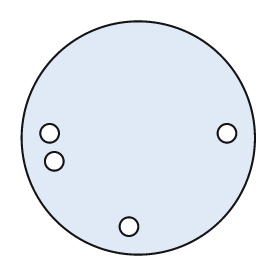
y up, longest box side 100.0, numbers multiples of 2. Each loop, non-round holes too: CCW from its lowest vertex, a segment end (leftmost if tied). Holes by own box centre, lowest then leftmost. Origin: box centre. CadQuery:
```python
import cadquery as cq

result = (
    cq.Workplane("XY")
    .moveTo(0.0, 0.0)
    .circle(50.0)
    .moveTo(-4.0, -38.0)
    .circle(4.0)
    .moveTo(-36.0, -10.0)
    .circle(4.0)
    .moveTo(-38.0, 2.0)
    .circle(4.0)
    .moveTo(38.0, 2.0)
    .circle(4.0)
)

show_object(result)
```